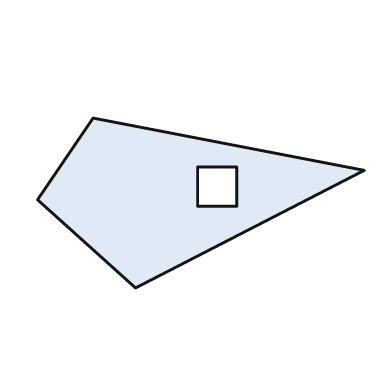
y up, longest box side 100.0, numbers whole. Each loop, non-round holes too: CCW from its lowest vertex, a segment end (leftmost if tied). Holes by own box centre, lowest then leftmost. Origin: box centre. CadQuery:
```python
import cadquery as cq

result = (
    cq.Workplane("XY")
    .moveTo(-20.0, -26.0)
    .lineTo(50.0, 10.0)
    .lineTo(-33.0, 26.0)
    .lineTo(-50.0, 1.0)
    .close()
    .moveTo(-1.0, -1.0)
    .lineTo(11.0, -1.0)
    .lineTo(11.0, 11.0)
    .lineTo(-1.0, 11.0)
    .close()
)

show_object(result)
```